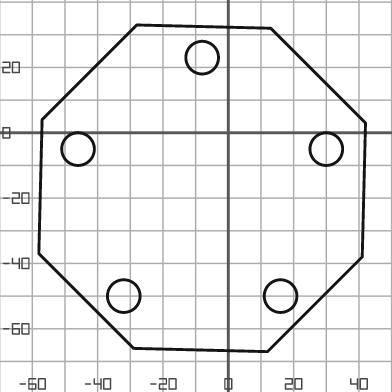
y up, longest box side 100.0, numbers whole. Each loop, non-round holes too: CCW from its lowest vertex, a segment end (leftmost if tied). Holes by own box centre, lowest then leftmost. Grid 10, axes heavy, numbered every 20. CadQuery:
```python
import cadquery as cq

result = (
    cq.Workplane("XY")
    .moveTo(12.0, -67.0)
    .lineTo(41.0, -38.0)
    .lineTo(42.0, 3.0)
    .lineTo(13.0, 32.0)
    .lineTo(-28.0, 33.0)
    .lineTo(-57.0, 4.0)
    .lineTo(-58.0, -37.0)
    .lineTo(-29.0, -66.0)
    .close()
    .moveTo(-32.0, -50.0)
    .circle(5.0)
    .moveTo(16.0, -50.0)
    .circle(5.0)
    .moveTo(-46.0, -5.0)
    .circle(5.0)
    .moveTo(30.0, -5.0)
    .circle(5.0)
    .moveTo(-8.0, 23.0)
    .circle(5.0)
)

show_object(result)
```